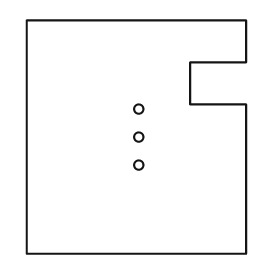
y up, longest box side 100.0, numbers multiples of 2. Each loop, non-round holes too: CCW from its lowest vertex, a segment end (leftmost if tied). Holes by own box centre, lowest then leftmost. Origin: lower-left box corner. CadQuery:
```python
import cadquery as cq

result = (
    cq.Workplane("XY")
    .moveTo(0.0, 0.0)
    .lineTo(94.0, 0.0)
    .lineTo(94.0, 64.0)
    .lineTo(70.0, 64.0)
    .lineTo(70.0, 82.0)
    .lineTo(94.0, 82.0)
    .lineTo(94.0, 100.0)
    .lineTo(0.0, 100.0)
    .close()
    .moveTo(48.0, 38.0)
    .circle(2.0)
    .moveTo(48.0, 50.0)
    .circle(2.0)
    .moveTo(48.0, 62.0)
    .circle(2.0)
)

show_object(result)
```